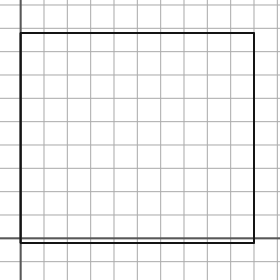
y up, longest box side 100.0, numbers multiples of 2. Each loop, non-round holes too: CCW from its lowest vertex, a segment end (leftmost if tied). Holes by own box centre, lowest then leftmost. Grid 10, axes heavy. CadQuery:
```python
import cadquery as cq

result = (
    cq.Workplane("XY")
    .moveTo(0.0, -2.0)
    .lineTo(100.0, -2.0)
    .lineTo(100.0, 88.0)
    .lineTo(0.0, 88.0)
    .close()
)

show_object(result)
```